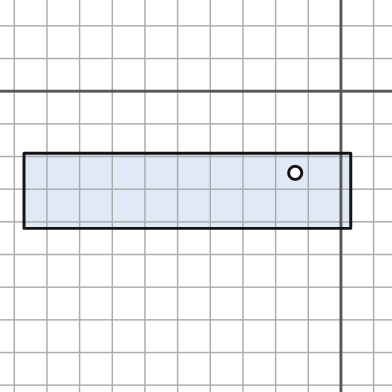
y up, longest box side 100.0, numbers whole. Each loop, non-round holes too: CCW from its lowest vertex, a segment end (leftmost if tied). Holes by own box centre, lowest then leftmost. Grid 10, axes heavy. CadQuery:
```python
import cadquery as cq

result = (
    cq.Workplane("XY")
    .moveTo(-97.0, -42.0)
    .lineTo(3.0, -42.0)
    .lineTo(3.0, -19.0)
    .lineTo(-97.0, -19.0)
    .close()
    .moveTo(-14.0, -25.0)
    .circle(2.0)
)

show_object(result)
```